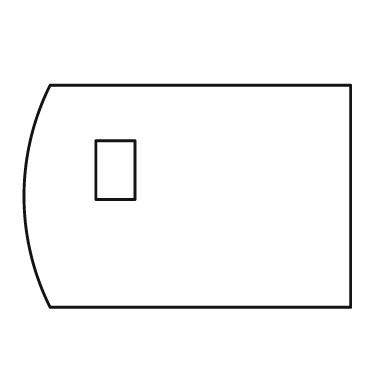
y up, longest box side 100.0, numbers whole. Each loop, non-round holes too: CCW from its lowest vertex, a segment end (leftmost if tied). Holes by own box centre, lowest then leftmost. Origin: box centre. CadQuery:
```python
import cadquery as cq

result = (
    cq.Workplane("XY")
    .moveTo(-42.0, -34.0)
    .lineTo(50.0, -34.0)
    .lineTo(50.0, 34.0)
    .lineTo(-42.0, 34.0)
    .threePointArc((-50.0, 0.0), (-42.0, -34.0))
    .close()
    .moveTo(-28.0, -1.0)
    .lineTo(-16.0, -1.0)
    .lineTo(-16.0, 17.0)
    .lineTo(-28.0, 17.0)
    .close()
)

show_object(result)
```